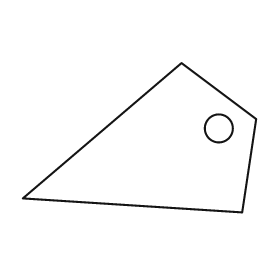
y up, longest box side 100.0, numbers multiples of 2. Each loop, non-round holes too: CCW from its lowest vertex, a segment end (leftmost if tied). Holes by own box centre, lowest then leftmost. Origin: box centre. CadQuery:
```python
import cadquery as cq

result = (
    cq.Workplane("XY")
    .moveTo(44.0, -32.0)
    .lineTo(50.0, 8.0)
    .lineTo(18.0, 32.0)
    .lineTo(-50.0, -26.0)
    .close()
    .moveTo(34.0, 4.0)
    .circle(6.0)
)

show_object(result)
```